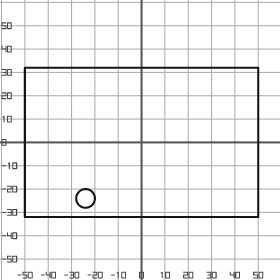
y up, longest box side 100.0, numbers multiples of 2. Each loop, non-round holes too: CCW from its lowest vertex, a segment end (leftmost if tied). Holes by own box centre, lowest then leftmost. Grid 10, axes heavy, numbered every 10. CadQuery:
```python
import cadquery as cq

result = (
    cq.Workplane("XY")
    .moveTo(-50.0, -32.0)
    .lineTo(50.0, -32.0)
    .lineTo(50.0, 32.0)
    .lineTo(-50.0, 32.0)
    .close()
    .moveTo(-24.0, -24.0)
    .circle(4.0)
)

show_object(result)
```